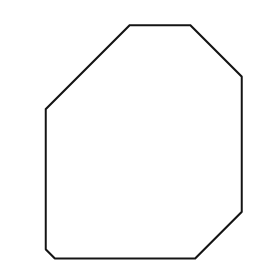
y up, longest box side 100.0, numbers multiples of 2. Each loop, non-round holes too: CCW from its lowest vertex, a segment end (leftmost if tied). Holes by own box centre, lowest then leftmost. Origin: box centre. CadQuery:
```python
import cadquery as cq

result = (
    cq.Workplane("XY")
    .moveTo(-38.0, -50.0)
    .lineTo(22.0, -50.0)
    .lineTo(42.0, -30.0)
    .lineTo(42.0, 28.0)
    .lineTo(20.0, 50.0)
    .lineTo(-6.0, 50.0)
    .lineTo(-42.0, 14.0)
    .lineTo(-42.0, -46.0)
    .close()
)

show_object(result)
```